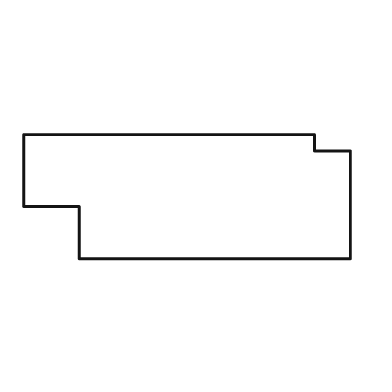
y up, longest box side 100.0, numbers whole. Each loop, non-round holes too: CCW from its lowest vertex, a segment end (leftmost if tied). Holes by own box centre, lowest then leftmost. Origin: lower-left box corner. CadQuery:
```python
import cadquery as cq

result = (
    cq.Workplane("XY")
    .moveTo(17.0, 0.0)
    .lineTo(100.0, 0.0)
    .lineTo(100.0, 33.0)
    .lineTo(89.0, 33.0)
    .lineTo(89.0, 38.0)
    .lineTo(0.0, 38.0)
    .lineTo(0.0, 16.0)
    .lineTo(17.0, 16.0)
    .close()
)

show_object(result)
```